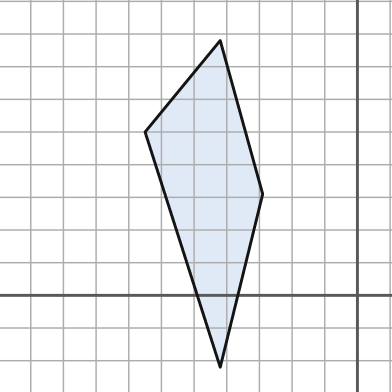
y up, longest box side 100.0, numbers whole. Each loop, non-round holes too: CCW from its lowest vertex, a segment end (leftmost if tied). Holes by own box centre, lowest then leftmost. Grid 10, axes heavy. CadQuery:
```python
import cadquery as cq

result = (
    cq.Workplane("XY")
    .moveTo(-42.0, -22.0)
    .lineTo(-29.0, 31.0)
    .lineTo(-42.0, 78.0)
    .lineTo(-65.0, 50.0)
    .close()
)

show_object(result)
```